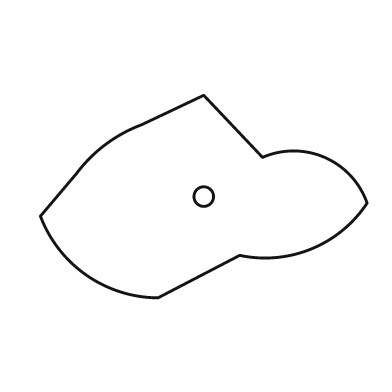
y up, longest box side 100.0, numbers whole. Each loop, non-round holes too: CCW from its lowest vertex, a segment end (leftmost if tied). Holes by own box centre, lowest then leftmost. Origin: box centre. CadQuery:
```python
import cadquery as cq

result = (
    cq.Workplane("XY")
    .moveTo(-14.0, -31.0)
    .lineTo(11.0, -18.0)
    .threePointArc((33.0, -16.0), (50.0, -2.0))
    .threePointArc((37.0, 12.0), (18.0, 12.0))
    .lineTo(0.0, 31.0)
    .lineTo(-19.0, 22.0)
    .threePointArc((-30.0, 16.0), (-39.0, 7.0))
    .lineTo(-50.0, -6.0)
    .threePointArc((-36.0, -24.0), (-14.0, -31.0))
    .close()
    .moveTo(0.0, 0.0)
    .circle(3.0)
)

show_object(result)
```